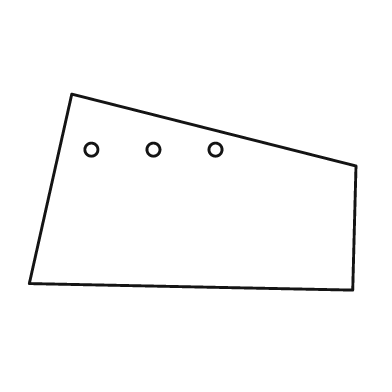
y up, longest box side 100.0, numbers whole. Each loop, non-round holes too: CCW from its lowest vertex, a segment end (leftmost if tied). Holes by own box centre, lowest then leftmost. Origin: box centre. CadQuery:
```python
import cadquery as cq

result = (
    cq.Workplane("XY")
    .moveTo(49.0, -30.0)
    .lineTo(50.0, 8.0)
    .lineTo(-37.0, 30.0)
    .lineTo(-50.0, -28.0)
    .close()
    .moveTo(-31.0, 13.0)
    .circle(2.0)
    .moveTo(-12.0, 13.0)
    .circle(2.0)
    .moveTo(7.0, 13.0)
    .circle(2.0)
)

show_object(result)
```